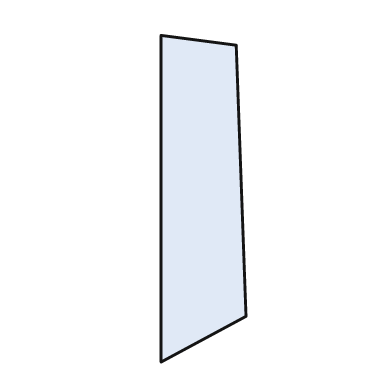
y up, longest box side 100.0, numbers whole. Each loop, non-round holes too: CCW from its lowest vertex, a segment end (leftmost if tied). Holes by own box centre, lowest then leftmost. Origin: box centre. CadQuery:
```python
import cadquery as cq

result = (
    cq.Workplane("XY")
    .moveTo(-13.0, -50.0)
    .lineTo(13.0, -36.0)
    .lineTo(10.0, 47.0)
    .lineTo(-13.0, 50.0)
    .close()
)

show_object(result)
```